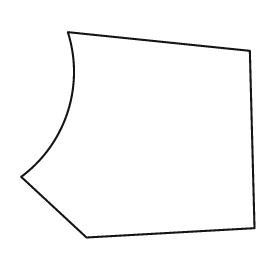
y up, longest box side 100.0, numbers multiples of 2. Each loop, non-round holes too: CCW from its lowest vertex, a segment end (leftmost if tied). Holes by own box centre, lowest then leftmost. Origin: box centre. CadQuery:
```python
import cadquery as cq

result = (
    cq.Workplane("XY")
    .moveTo(-22.0, -44.0)
    .lineTo(50.0, -40.0)
    .lineTo(48.0, 36.0)
    .lineTo(-30.0, 44.0)
    .threePointArc((-30.0, 10.0), (-50.0, -18.0))
    .close()
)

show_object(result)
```